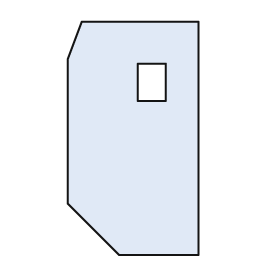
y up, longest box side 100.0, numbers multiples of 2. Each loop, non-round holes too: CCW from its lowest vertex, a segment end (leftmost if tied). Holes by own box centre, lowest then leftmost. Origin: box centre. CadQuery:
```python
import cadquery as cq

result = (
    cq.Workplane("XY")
    .moveTo(-6.0, -50.0)
    .lineTo(28.0, -50.0)
    .lineTo(28.0, 50.0)
    .lineTo(-22.0, 50.0)
    .lineTo(-28.0, 34.0)
    .lineTo(-28.0, -28.0)
    .close()
    .moveTo(2.0, 16.0)
    .lineTo(14.0, 16.0)
    .lineTo(14.0, 32.0)
    .lineTo(2.0, 32.0)
    .close()
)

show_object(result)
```